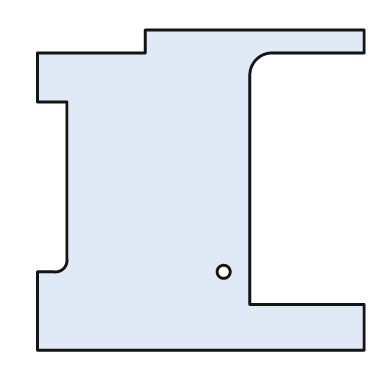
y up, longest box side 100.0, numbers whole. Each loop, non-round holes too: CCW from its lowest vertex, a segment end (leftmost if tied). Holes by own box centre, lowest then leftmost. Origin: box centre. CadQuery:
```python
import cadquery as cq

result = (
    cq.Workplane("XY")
    .moveTo(-50.0, -49.0)
    .lineTo(50.0, -49.0)
    .lineTo(50.0, -35.0)
    .lineTo(15.0, -35.0)
    .lineTo(15.0, 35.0)
    .threePointArc((17.0, 40.0), (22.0, 42.0))
    .lineTo(50.0, 42.0)
    .lineTo(50.0, 49.0)
    .lineTo(-17.0, 49.0)
    .lineTo(-17.0, 42.0)
    .lineTo(-50.0, 42.0)
    .lineTo(-50.0, 27.0)
    .lineTo(-41.0, 27.0)
    .lineTo(-41.0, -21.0)
    .threePointArc((-42.0, -24.0), (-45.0, -25.0))
    .lineTo(-50.0, -25.0)
    .close()
    .moveTo(7.0, -25.0)
    .circle(2.0)
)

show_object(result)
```